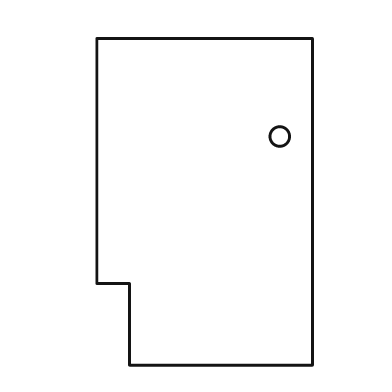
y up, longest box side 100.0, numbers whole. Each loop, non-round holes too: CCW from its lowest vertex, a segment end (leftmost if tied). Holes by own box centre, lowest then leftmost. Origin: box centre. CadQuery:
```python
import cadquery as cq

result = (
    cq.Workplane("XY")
    .moveTo(-23.0, -50.0)
    .lineTo(33.0, -50.0)
    .lineTo(33.0, 50.0)
    .lineTo(-33.0, 50.0)
    .lineTo(-33.0, -25.0)
    .lineTo(-23.0, -25.0)
    .close()
    .moveTo(23.0, 20.0)
    .circle(3.0)
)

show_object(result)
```